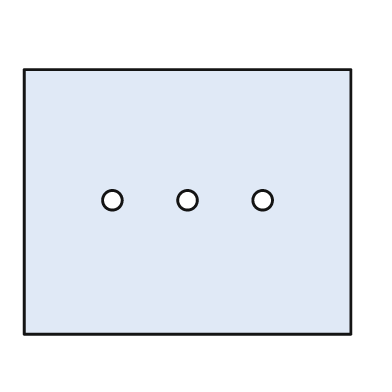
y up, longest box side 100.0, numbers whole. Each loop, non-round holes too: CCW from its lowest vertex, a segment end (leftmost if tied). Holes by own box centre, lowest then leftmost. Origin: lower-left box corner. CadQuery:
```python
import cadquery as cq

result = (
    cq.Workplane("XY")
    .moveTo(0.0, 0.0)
    .lineTo(100.0, 0.0)
    .lineTo(100.0, 81.0)
    .lineTo(0.0, 81.0)
    .close()
    .moveTo(27.0, 41.0)
    .circle(3.0)
    .moveTo(50.0, 41.0)
    .circle(3.0)
    .moveTo(73.0, 41.0)
    .circle(3.0)
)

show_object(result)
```